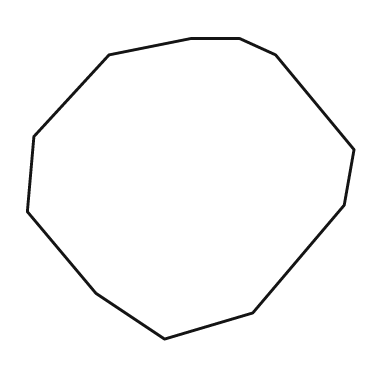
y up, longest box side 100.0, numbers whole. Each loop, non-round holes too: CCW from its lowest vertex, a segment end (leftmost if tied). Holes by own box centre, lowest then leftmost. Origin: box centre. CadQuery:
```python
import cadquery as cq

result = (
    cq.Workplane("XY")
    .moveTo(-8.0, -46.0)
    .lineTo(19.0, -38.0)
    .lineTo(47.0, -5.0)
    .lineTo(50.0, 12.0)
    .lineTo(26.0, 41.0)
    .lineTo(15.0, 46.0)
    .lineTo(0.0, 46.0)
    .lineTo(-25.0, 41.0)
    .lineTo(-48.0, 16.0)
    .lineTo(-50.0, -7.0)
    .lineTo(-29.0, -32.0)
    .close()
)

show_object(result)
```